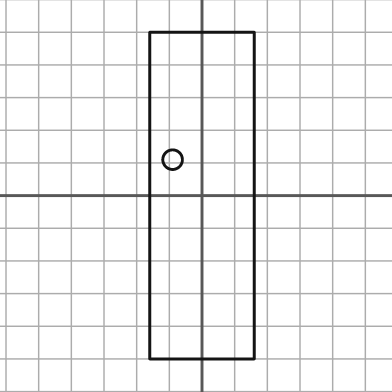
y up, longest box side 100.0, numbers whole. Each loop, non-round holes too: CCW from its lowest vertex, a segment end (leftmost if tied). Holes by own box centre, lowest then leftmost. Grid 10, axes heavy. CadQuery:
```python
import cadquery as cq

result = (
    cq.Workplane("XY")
    .moveTo(-16.0, -50.0)
    .lineTo(16.0, -50.0)
    .lineTo(16.0, 50.0)
    .lineTo(-16.0, 50.0)
    .close()
    .moveTo(-9.0, 11.0)
    .circle(3.0)
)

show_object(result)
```